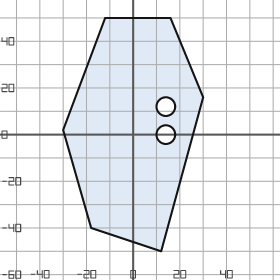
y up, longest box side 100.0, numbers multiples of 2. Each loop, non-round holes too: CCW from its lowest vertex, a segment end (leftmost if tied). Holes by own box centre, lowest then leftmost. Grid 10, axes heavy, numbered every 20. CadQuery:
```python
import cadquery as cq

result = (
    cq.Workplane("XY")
    .moveTo(12.0, -50.0)
    .lineTo(30.0, 16.0)
    .lineTo(16.0, 50.0)
    .lineTo(-12.0, 50.0)
    .lineTo(-30.0, 2.0)
    .lineTo(-18.0, -40.0)
    .close()
    .moveTo(14.0, 0.0)
    .circle(4.0)
    .moveTo(14.0, 12.0)
    .circle(4.0)
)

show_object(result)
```